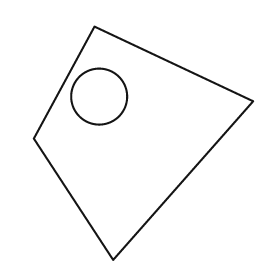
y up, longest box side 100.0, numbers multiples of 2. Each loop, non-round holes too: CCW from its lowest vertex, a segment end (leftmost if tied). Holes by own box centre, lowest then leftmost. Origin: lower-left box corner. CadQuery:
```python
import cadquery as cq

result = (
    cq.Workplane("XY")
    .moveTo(34.0, 0.0)
    .lineTo(94.0, 68.0)
    .lineTo(26.0, 100.0)
    .lineTo(0.0, 52.0)
    .close()
    .moveTo(28.0, 70.0)
    .circle(12.0)
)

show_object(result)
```